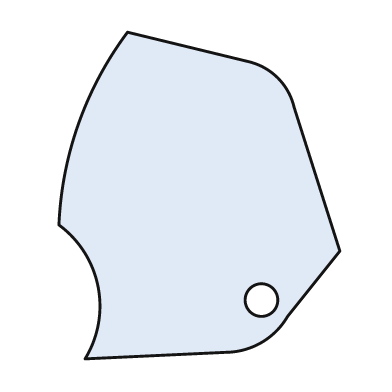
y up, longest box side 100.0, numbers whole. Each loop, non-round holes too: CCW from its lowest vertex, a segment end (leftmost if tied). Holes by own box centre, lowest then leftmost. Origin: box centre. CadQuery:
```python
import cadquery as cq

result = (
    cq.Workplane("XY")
    .moveTo(-35.0, -50.0)
    .lineTo(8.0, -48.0)
    .threePointArc((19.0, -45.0), (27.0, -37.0))
    .lineTo(43.0, -17.0)
    .lineTo(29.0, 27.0)
    .threePointArc((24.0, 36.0), (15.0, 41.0))
    .lineTo(-22.0, 50.0)
    .threePointArc((-37.0, 22.0), (-43.0, -9.0))
    .threePointArc((-31.0, -28.0), (-35.0, -50.0))
    .close()
    .moveTo(19.0, -32.0)
    .circle(5.0)
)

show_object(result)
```